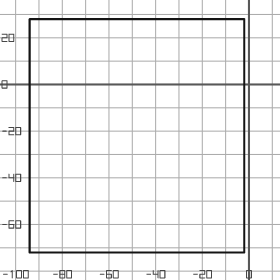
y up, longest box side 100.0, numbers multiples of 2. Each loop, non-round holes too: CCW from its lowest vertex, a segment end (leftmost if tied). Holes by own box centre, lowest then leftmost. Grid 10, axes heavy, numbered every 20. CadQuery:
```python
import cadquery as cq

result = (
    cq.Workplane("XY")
    .moveTo(-94.0, -72.0)
    .lineTo(-2.0, -72.0)
    .lineTo(-2.0, 28.0)
    .lineTo(-94.0, 28.0)
    .close()
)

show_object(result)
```